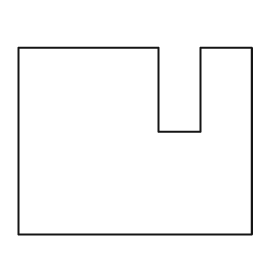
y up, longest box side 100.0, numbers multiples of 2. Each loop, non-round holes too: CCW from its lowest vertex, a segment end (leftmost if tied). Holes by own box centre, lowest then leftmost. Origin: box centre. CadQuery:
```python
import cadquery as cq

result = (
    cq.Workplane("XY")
    .moveTo(-50.0, -40.0)
    .lineTo(50.0, -40.0)
    .lineTo(50.0, 40.0)
    .lineTo(28.0, 40.0)
    .lineTo(28.0, 4.0)
    .lineTo(10.0, 4.0)
    .lineTo(10.0, 40.0)
    .lineTo(-50.0, 40.0)
    .close()
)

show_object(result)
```